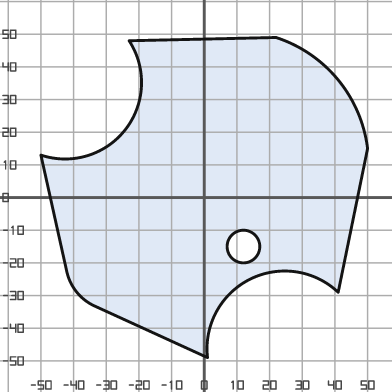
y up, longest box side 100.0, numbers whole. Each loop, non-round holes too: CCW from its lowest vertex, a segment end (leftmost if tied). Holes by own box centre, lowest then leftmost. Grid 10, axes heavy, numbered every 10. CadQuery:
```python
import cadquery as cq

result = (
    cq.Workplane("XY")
    .moveTo(1.0, -49.0)
    .threePointArc((14.0, -25.0), (41.0, -29.0))
    .lineTo(50.0, 15.0)
    .threePointArc((41.0, 36.0), (22.0, 49.0))
    .lineTo(-23.0, 48.0)
    .threePointArc((-24.0, 21.0), (-50.0, 13.0))
    .lineTo(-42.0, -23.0)
    .threePointArc((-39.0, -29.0), (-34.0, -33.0))
    .close()
    .moveTo(12.0, -15.0)
    .circle(5.0)
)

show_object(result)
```